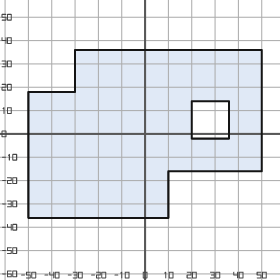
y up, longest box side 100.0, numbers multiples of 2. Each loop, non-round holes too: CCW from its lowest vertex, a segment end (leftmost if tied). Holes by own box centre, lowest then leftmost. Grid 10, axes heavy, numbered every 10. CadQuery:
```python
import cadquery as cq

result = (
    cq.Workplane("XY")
    .moveTo(-50.0, -36.0)
    .lineTo(10.0, -36.0)
    .lineTo(10.0, -16.0)
    .lineTo(50.0, -16.0)
    .lineTo(50.0, 36.0)
    .lineTo(-30.0, 36.0)
    .lineTo(-30.0, 18.0)
    .lineTo(-50.0, 18.0)
    .close()
    .moveTo(20.0, -2.0)
    .lineTo(36.0, -2.0)
    .lineTo(36.0, 14.0)
    .lineTo(20.0, 14.0)
    .close()
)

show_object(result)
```